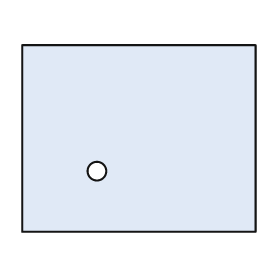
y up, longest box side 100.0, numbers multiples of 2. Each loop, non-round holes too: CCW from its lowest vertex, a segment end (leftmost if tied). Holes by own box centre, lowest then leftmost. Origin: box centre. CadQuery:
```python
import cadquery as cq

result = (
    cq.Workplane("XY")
    .moveTo(-50.0, -40.0)
    .lineTo(50.0, -40.0)
    .lineTo(50.0, 40.0)
    .lineTo(-50.0, 40.0)
    .close()
    .moveTo(-18.0, -14.0)
    .circle(4.0)
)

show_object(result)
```